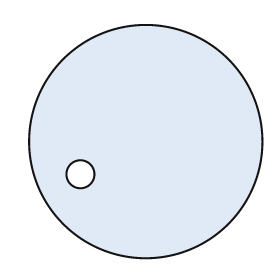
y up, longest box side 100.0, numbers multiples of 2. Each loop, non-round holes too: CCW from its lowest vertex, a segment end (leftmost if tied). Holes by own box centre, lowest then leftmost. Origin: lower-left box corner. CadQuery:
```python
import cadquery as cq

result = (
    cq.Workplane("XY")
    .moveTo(50.0, 50.0)
    .circle(50.0)
    .moveTo(22.0, 36.0)
    .circle(6.0)
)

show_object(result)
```